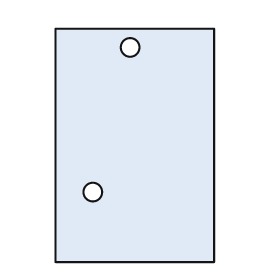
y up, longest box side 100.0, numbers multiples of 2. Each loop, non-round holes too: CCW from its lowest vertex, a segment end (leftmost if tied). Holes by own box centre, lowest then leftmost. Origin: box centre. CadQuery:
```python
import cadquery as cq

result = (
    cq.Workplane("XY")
    .moveTo(-34.0, -50.0)
    .lineTo(34.0, -50.0)
    .lineTo(34.0, 50.0)
    .lineTo(-34.0, 50.0)
    .close()
    .moveTo(-18.0, -20.0)
    .circle(4.0)
    .moveTo(-2.0, 42.0)
    .circle(4.0)
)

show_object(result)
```